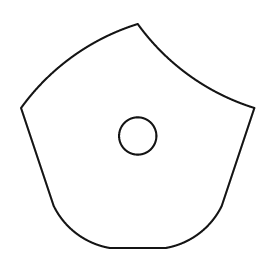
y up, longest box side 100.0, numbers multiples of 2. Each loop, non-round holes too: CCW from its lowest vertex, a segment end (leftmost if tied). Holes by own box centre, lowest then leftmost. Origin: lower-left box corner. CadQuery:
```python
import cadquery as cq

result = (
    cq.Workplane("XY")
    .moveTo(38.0, 0.0)
    .lineTo(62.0, 0.0)
    .threePointArc((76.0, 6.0), (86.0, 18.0))
    .lineTo(100.0, 60.0)
    .threePointArc((72.0, 74.0), (50.0, 96.0))
    .threePointArc((22.0, 82.0), (0.0, 60.0))
    .lineTo(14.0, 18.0)
    .threePointArc((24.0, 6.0), (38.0, 0.0))
    .close()
    .moveTo(50.0, 48.0)
    .circle(8.0)
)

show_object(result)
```